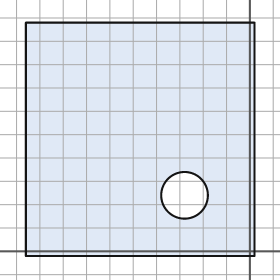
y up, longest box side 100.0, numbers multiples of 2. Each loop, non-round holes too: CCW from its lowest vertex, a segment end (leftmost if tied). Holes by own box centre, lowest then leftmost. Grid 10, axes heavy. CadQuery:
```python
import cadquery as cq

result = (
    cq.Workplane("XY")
    .moveTo(-96.0, -2.0)
    .lineTo(2.0, -2.0)
    .lineTo(2.0, 98.0)
    .lineTo(-96.0, 98.0)
    .close()
    .moveTo(-28.0, 24.0)
    .circle(10.0)
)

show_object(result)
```